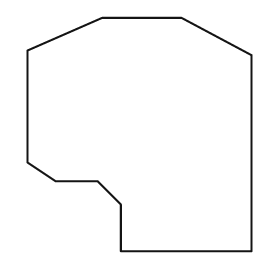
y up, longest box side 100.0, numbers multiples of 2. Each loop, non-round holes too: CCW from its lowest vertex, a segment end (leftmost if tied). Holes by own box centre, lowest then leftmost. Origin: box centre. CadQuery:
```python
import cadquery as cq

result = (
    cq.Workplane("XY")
    .moveTo(-8.0, -50.0)
    .lineTo(48.0, -50.0)
    .lineTo(48.0, 34.0)
    .lineTo(18.0, 50.0)
    .lineTo(-16.0, 50.0)
    .lineTo(-48.0, 36.0)
    .lineTo(-48.0, -12.0)
    .lineTo(-36.0, -20.0)
    .lineTo(-18.0, -20.0)
    .lineTo(-8.0, -30.0)
    .close()
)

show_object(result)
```